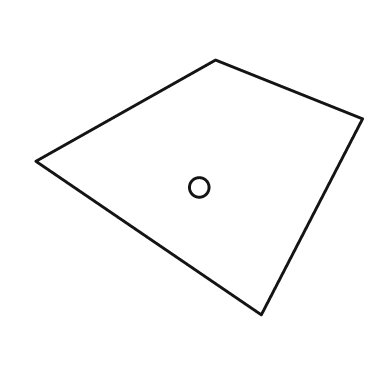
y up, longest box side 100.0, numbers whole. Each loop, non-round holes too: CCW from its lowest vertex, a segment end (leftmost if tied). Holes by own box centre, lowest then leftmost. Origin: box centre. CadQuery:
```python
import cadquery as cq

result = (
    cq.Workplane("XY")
    .moveTo(19.0, -39.0)
    .lineTo(50.0, 21.0)
    .lineTo(5.0, 39.0)
    .lineTo(-50.0, 8.0)
    .close()
    .moveTo(0.0, 0.0)
    .circle(3.0)
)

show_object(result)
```